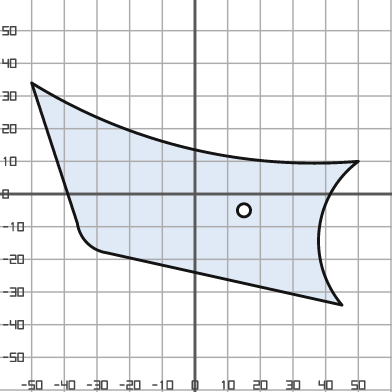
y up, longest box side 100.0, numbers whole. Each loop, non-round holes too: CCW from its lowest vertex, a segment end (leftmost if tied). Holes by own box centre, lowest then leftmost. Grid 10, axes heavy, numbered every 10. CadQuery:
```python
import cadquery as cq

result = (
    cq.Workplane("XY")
    .moveTo(45.0, -34.0)
    .threePointArc((38.0, -11.0), (50.0, 10.0))
    .threePointArc((-2.0, 14.0), (-50.0, 34.0))
    .lineTo(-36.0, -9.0)
    .threePointArc((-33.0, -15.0), (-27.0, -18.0))
    .close()
    .moveTo(15.0, -5.0)
    .circle(2.0)
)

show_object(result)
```